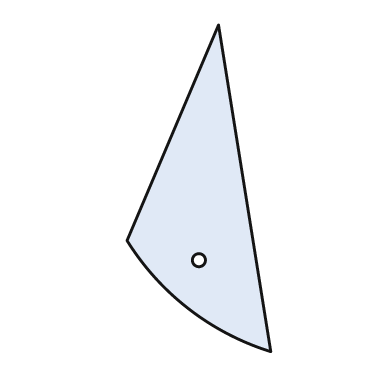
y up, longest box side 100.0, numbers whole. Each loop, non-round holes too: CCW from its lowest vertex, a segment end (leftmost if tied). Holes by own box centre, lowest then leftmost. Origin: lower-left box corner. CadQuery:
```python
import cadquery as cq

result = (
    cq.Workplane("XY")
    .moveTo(44.0, 0.0)
    .lineTo(28.0, 100.0)
    .lineTo(0.0, 34.0)
    .threePointArc((19.0, 13.0), (44.0, 0.0))
    .close()
    .moveTo(22.0, 28.0)
    .circle(2.0)
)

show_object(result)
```